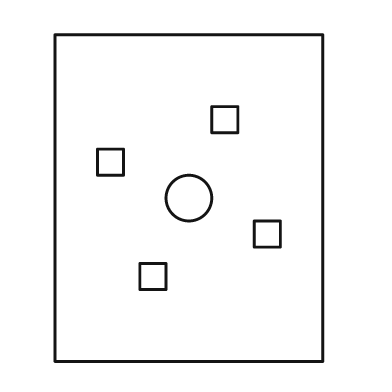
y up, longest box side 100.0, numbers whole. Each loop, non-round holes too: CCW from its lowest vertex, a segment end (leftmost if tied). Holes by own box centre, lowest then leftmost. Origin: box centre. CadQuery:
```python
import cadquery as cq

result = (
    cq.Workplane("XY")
    .moveTo(-41.0, -50.0)
    .lineTo(41.0, -50.0)
    .lineTo(41.0, 50.0)
    .lineTo(-41.0, 50.0)
    .close()
    .moveTo(-15.0, -28.0)
    .lineTo(-7.0, -28.0)
    .lineTo(-7.0, -20.0)
    .lineTo(-15.0, -20.0)
    .close()
    .moveTo(20.0, -15.0)
    .lineTo(28.0, -15.0)
    .lineTo(28.0, -7.0)
    .lineTo(20.0, -7.0)
    .close()
    .moveTo(0.0, 0.0)
    .circle(7.0)
    .moveTo(-28.0, 7.0)
    .lineTo(-20.0, 7.0)
    .lineTo(-20.0, 15.0)
    .lineTo(-28.0, 15.0)
    .close()
    .moveTo(7.0, 20.0)
    .lineTo(15.0, 20.0)
    .lineTo(15.0, 28.0)
    .lineTo(7.0, 28.0)
    .close()
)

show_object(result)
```